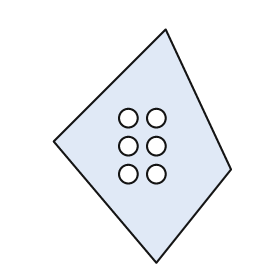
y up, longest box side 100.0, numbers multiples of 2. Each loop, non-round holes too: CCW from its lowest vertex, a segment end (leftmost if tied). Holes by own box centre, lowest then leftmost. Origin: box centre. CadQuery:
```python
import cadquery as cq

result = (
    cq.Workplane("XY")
    .moveTo(6.0, -50.0)
    .lineTo(38.0, -10.0)
    .lineTo(10.0, 50.0)
    .lineTo(-38.0, 2.0)
    .close()
    .moveTo(-6.0, -12.0)
    .circle(4.0)
    .moveTo(6.0, -12.0)
    .circle(4.0)
    .moveTo(-6.0, 0.0)
    .circle(4.0)
    .moveTo(6.0, 0.0)
    .circle(4.0)
    .moveTo(-6.0, 12.0)
    .circle(4.0)
    .moveTo(6.0, 12.0)
    .circle(4.0)
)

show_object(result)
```